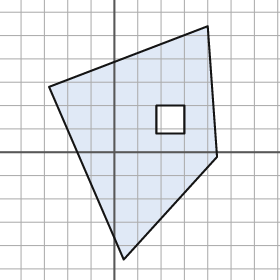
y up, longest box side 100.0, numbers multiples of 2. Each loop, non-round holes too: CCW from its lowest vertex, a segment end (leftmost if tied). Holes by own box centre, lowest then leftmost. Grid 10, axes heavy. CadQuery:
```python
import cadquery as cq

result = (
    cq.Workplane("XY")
    .moveTo(4.0, -46.0)
    .lineTo(44.0, -2.0)
    .lineTo(40.0, 54.0)
    .lineTo(-28.0, 28.0)
    .close()
    .moveTo(18.0, 8.0)
    .lineTo(30.0, 8.0)
    .lineTo(30.0, 20.0)
    .lineTo(18.0, 20.0)
    .close()
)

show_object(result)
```